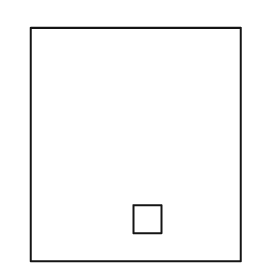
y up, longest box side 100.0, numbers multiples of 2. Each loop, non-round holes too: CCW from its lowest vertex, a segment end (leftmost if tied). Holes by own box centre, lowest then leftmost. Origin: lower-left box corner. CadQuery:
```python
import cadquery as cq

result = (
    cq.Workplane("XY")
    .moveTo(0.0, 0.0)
    .lineTo(90.0, 0.0)
    .lineTo(90.0, 100.0)
    .lineTo(0.0, 100.0)
    .close()
    .moveTo(44.0, 12.0)
    .lineTo(56.0, 12.0)
    .lineTo(56.0, 24.0)
    .lineTo(44.0, 24.0)
    .close()
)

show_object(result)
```